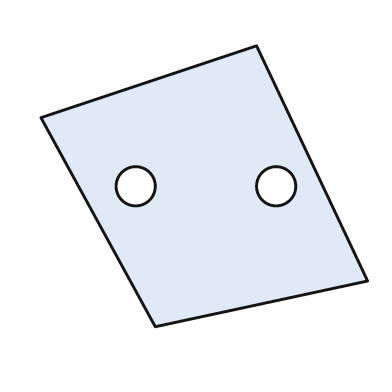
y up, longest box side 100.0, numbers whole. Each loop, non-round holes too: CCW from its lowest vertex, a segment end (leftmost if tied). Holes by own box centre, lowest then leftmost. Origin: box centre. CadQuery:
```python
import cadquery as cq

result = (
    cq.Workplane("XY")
    .moveTo(-15.0, -43.0)
    .lineTo(50.0, -29.0)
    .lineTo(16.0, 43.0)
    .lineTo(-50.0, 21.0)
    .close()
    .moveTo(-21.0, 0.0)
    .circle(6.0)
    .moveTo(22.0, 0.0)
    .circle(6.0)
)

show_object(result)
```